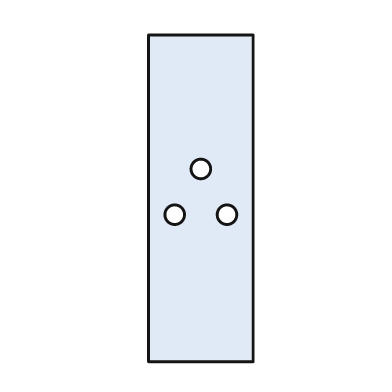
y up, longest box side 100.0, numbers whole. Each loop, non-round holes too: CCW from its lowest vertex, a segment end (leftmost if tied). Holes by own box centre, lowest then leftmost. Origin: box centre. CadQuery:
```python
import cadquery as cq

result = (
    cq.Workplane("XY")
    .moveTo(-16.0, -50.0)
    .lineTo(16.0, -50.0)
    .lineTo(16.0, 50.0)
    .lineTo(-16.0, 50.0)
    .close()
    .moveTo(-8.0, -5.0)
    .circle(3.0)
    .moveTo(8.0, -5.0)
    .circle(3.0)
    .moveTo(0.0, 9.0)
    .circle(3.0)
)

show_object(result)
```